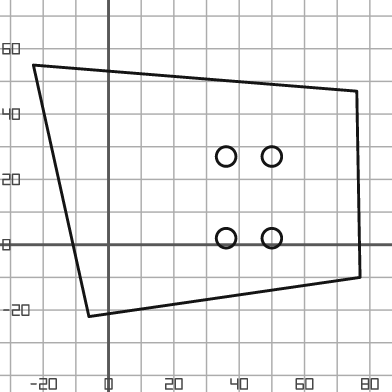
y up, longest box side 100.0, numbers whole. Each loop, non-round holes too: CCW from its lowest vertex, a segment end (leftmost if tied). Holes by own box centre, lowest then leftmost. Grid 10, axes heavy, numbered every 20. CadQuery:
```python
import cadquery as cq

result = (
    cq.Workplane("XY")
    .moveTo(-6.0, -22.0)
    .lineTo(77.0, -10.0)
    .lineTo(76.0, 47.0)
    .lineTo(-23.0, 55.0)
    .close()
    .moveTo(36.0, 2.0)
    .circle(3.0)
    .moveTo(50.0, 2.0)
    .circle(3.0)
    .moveTo(36.0, 27.0)
    .circle(3.0)
    .moveTo(50.0, 27.0)
    .circle(3.0)
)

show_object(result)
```